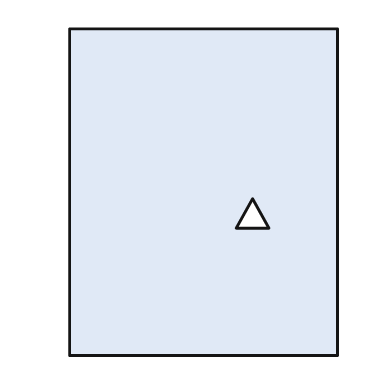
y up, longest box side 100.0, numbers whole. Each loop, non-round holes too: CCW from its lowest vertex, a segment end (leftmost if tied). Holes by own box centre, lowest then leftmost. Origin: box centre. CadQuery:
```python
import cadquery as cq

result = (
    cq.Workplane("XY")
    .moveTo(-41.0, -50.0)
    .lineTo(41.0, -50.0)
    .lineTo(41.0, 50.0)
    .lineTo(-41.0, 50.0)
    .close()
    .moveTo(10.0, -11.0)
    .lineTo(20.0, -11.0)
    .lineTo(15.0, -2.0)
    .close()
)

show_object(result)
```